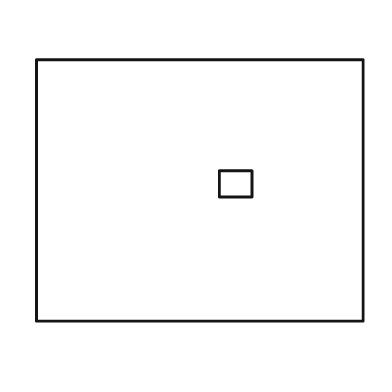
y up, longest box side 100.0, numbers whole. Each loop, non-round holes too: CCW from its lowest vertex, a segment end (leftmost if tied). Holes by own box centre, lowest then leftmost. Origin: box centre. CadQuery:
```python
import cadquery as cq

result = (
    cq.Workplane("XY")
    .moveTo(-50.0, -40.0)
    .lineTo(50.0, -40.0)
    .lineTo(50.0, 40.0)
    .lineTo(-50.0, 40.0)
    .close()
    .moveTo(6.0, -2.0)
    .lineTo(16.0, -2.0)
    .lineTo(16.0, 6.0)
    .lineTo(6.0, 6.0)
    .close()
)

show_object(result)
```